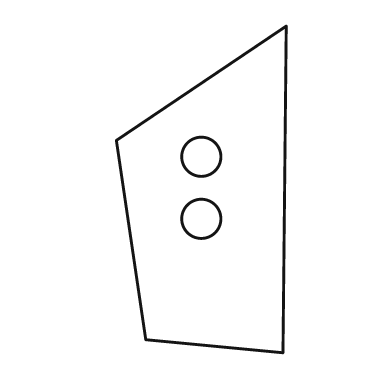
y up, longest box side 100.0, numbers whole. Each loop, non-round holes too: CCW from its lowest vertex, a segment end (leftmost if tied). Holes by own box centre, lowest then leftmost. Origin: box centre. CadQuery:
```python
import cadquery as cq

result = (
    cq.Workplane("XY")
    .moveTo(25.0, -50.0)
    .lineTo(26.0, 50.0)
    .lineTo(-26.0, 15.0)
    .lineTo(-17.0, -46.0)
    .close()
    .moveTo(0.0, -9.0)
    .circle(6.0)
    .moveTo(0.0, 10.0)
    .circle(6.0)
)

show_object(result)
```